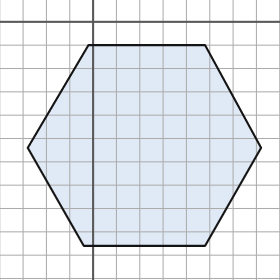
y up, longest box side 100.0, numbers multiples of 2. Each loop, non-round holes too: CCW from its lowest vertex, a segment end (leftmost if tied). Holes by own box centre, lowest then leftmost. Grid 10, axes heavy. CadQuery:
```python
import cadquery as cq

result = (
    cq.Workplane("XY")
    .moveTo(-4.0, -96.0)
    .lineTo(48.0, -96.0)
    .lineTo(72.0, -54.0)
    .lineTo(48.0, -10.0)
    .lineTo(-2.0, -10.0)
    .lineTo(-28.0, -54.0)
    .close()
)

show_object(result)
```